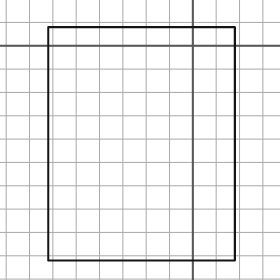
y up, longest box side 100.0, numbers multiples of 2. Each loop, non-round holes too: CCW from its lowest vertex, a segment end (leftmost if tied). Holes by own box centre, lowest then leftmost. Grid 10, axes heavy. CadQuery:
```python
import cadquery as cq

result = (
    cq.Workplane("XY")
    .moveTo(-62.0, -92.0)
    .lineTo(18.0, -92.0)
    .lineTo(18.0, 8.0)
    .lineTo(-62.0, 8.0)
    .close()
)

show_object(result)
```